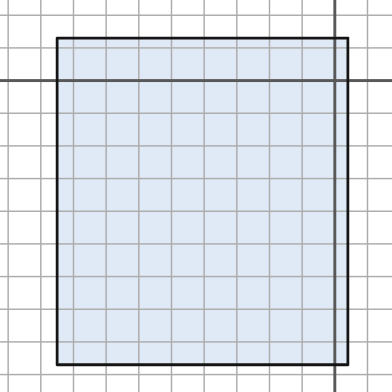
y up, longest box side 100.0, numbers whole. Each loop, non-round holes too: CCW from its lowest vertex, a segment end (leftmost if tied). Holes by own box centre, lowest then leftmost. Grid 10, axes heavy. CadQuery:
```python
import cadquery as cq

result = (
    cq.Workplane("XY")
    .moveTo(-85.0, -87.0)
    .lineTo(4.0, -87.0)
    .lineTo(4.0, 13.0)
    .lineTo(-85.0, 13.0)
    .close()
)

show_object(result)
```